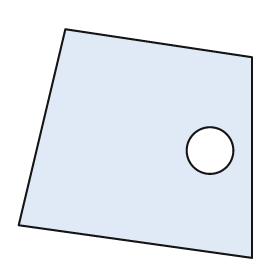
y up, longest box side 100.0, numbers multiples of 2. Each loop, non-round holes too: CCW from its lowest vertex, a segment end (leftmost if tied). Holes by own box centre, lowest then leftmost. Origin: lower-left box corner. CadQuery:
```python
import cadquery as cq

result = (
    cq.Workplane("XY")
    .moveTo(100.0, 0.0)
    .lineTo(100.0, 86.0)
    .lineTo(20.0, 98.0)
    .lineTo(0.0, 14.0)
    .close()
    .moveTo(82.0, 46.0)
    .circle(10.0)
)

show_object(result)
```